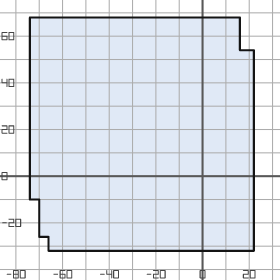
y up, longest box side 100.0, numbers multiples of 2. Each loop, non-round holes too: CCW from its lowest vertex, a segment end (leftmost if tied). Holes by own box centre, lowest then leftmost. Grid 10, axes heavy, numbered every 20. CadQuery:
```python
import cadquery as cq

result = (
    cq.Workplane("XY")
    .moveTo(-66.0, -32.0)
    .lineTo(22.0, -32.0)
    .lineTo(22.0, 54.0)
    .lineTo(16.0, 54.0)
    .lineTo(16.0, 68.0)
    .lineTo(-74.0, 68.0)
    .lineTo(-74.0, -10.0)
    .lineTo(-70.0, -10.0)
    .lineTo(-70.0, -26.0)
    .lineTo(-66.0, -26.0)
    .close()
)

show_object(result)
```